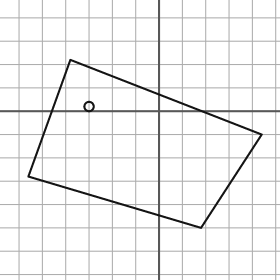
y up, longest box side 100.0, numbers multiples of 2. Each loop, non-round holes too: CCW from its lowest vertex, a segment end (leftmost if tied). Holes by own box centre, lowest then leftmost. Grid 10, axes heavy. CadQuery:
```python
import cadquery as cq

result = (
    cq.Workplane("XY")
    .moveTo(18.0, -50.0)
    .lineTo(44.0, -10.0)
    .lineTo(-38.0, 22.0)
    .lineTo(-56.0, -28.0)
    .close()
    .moveTo(-30.0, 2.0)
    .circle(2.0)
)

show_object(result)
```